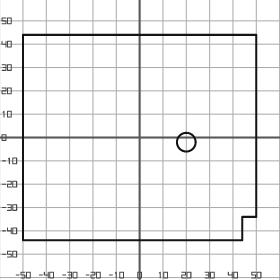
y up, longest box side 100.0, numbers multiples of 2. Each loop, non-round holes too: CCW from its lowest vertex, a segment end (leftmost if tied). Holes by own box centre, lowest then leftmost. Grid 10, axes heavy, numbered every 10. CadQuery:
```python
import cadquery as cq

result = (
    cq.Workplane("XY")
    .moveTo(-50.0, -44.0)
    .lineTo(44.0, -44.0)
    .lineTo(44.0, -34.0)
    .lineTo(50.0, -34.0)
    .lineTo(50.0, 44.0)
    .lineTo(-50.0, 44.0)
    .close()
    .moveTo(20.0, -2.0)
    .circle(4.0)
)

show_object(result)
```